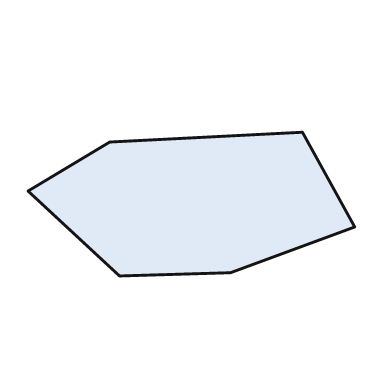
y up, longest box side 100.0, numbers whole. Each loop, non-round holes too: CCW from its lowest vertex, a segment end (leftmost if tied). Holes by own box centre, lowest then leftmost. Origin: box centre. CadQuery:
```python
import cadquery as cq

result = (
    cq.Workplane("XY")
    .moveTo(-22.0, -22.0)
    .lineTo(12.0, -21.0)
    .lineTo(50.0, -7.0)
    .lineTo(34.0, 22.0)
    .lineTo(-25.0, 19.0)
    .lineTo(-50.0, 4.0)
    .close()
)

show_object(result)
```